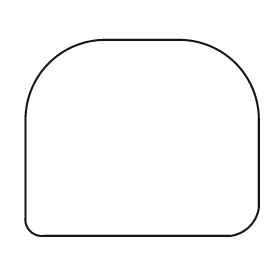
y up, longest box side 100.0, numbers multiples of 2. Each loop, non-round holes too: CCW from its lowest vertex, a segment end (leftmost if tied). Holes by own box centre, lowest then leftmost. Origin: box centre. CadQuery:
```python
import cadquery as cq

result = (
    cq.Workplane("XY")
    .moveTo(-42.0, -42.0)
    .lineTo(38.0, -42.0)
    .threePointArc((46.0, -38.0), (50.0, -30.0))
    .lineTo(50.0, 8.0)
    .threePointArc((40.0, 32.0), (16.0, 42.0))
    .lineTo(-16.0, 42.0)
    .threePointArc((-40.0, 32.0), (-50.0, 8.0))
    .lineTo(-50.0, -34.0)
    .threePointArc((-48.0, -40.0), (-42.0, -42.0))
    .close()
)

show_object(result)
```